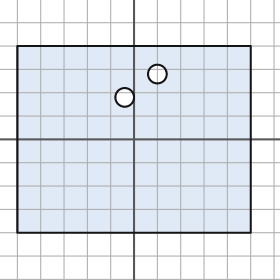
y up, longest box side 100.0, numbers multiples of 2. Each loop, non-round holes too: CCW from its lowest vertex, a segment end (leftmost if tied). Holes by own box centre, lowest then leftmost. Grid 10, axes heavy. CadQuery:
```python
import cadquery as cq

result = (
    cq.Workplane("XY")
    .moveTo(-50.0, -40.0)
    .lineTo(50.0, -40.0)
    .lineTo(50.0, 40.0)
    .lineTo(-50.0, 40.0)
    .close()
    .moveTo(-4.0, 18.0)
    .circle(4.0)
    .moveTo(10.0, 28.0)
    .circle(4.0)
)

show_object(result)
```